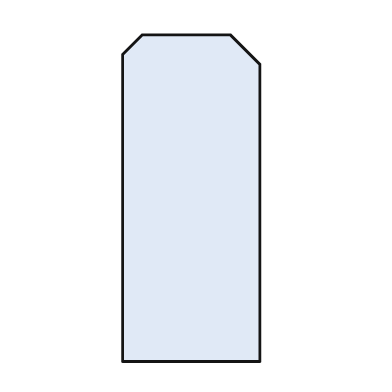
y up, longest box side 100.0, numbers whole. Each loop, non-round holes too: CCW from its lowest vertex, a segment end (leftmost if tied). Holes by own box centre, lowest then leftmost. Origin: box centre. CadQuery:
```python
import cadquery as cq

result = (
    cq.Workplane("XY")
    .moveTo(-21.0, -50.0)
    .lineTo(21.0, -50.0)
    .lineTo(21.0, 41.0)
    .lineTo(12.0, 50.0)
    .lineTo(-15.0, 50.0)
    .lineTo(-21.0, 44.0)
    .close()
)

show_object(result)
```